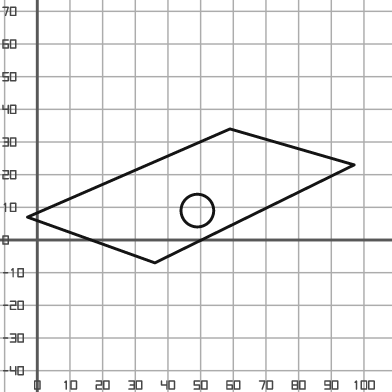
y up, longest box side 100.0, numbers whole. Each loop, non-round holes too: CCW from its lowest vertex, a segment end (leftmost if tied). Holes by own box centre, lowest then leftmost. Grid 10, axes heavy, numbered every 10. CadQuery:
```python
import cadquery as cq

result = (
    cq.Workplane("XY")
    .moveTo(36.0, -7.0)
    .lineTo(97.0, 23.0)
    .lineTo(59.0, 34.0)
    .lineTo(-3.0, 7.0)
    .close()
    .moveTo(49.0, 9.0)
    .circle(5.0)
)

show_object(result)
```